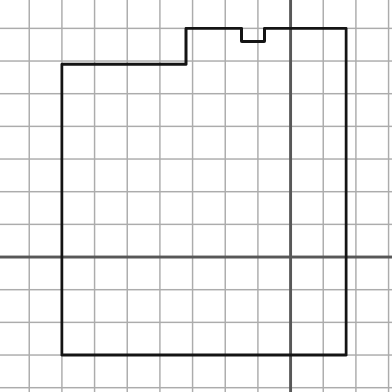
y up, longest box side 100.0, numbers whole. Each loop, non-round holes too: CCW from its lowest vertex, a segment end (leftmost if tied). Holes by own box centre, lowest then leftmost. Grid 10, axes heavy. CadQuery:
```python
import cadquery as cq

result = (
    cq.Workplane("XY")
    .moveTo(-70.0, -30.0)
    .lineTo(17.0, -30.0)
    .lineTo(17.0, 70.0)
    .lineTo(-8.0, 70.0)
    .lineTo(-8.0, 66.0)
    .lineTo(-15.0, 66.0)
    .lineTo(-15.0, 70.0)
    .lineTo(-32.0, 70.0)
    .lineTo(-32.0, 59.0)
    .lineTo(-70.0, 59.0)
    .close()
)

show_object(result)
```